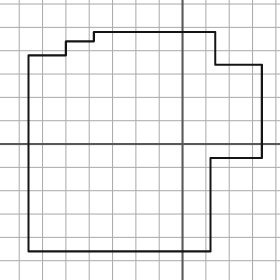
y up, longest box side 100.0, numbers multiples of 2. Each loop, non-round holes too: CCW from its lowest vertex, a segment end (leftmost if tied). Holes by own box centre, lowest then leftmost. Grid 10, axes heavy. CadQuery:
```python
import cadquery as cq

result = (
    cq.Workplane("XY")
    .moveTo(-66.0, -46.0)
    .lineTo(12.0, -46.0)
    .lineTo(12.0, -6.0)
    .lineTo(34.0, -6.0)
    .lineTo(34.0, 34.0)
    .lineTo(14.0, 34.0)
    .lineTo(14.0, 48.0)
    .lineTo(-38.0, 48.0)
    .lineTo(-38.0, 44.0)
    .lineTo(-50.0, 44.0)
    .lineTo(-50.0, 38.0)
    .lineTo(-66.0, 38.0)
    .close()
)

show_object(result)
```